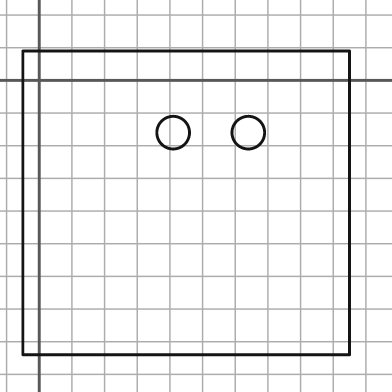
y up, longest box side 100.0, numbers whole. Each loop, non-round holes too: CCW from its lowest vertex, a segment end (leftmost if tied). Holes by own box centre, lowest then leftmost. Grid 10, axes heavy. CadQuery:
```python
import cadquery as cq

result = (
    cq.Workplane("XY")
    .moveTo(-5.0, -84.0)
    .lineTo(95.0, -84.0)
    .lineTo(95.0, 9.0)
    .lineTo(-5.0, 9.0)
    .close()
    .moveTo(41.0, -16.0)
    .circle(5.0)
    .moveTo(64.0, -16.0)
    .circle(5.0)
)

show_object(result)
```